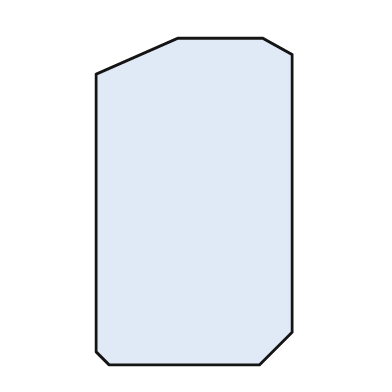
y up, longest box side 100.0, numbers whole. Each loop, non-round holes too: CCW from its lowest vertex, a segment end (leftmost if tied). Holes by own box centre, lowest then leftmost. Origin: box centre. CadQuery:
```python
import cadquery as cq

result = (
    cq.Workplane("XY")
    .moveTo(-26.0, -50.0)
    .lineTo(20.0, -50.0)
    .lineTo(30.0, -40.0)
    .lineTo(30.0, 45.0)
    .lineTo(21.0, 50.0)
    .lineTo(-5.0, 50.0)
    .lineTo(-30.0, 39.0)
    .lineTo(-30.0, -46.0)
    .close()
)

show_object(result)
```